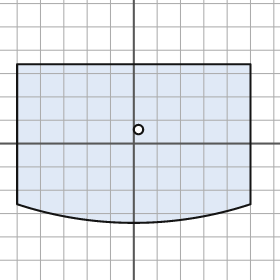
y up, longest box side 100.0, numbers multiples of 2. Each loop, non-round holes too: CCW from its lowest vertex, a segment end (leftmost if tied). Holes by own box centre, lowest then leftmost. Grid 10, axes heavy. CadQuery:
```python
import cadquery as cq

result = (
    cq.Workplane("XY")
    .moveTo(-50.0, -26.0)
    .threePointArc((0.0, -34.0), (50.0, -26.0))
    .lineTo(50.0, 34.0)
    .lineTo(-50.0, 34.0)
    .close()
    .moveTo(2.0, 6.0)
    .circle(2.0)
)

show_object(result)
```